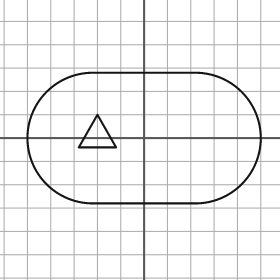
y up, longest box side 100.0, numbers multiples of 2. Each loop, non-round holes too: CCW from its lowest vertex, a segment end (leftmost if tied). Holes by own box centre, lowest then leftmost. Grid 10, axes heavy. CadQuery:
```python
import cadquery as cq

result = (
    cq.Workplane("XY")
    .moveTo(-22.0, -28.0)
    .lineTo(22.0, -28.0)
    .threePointArc((50.0, 0.0), (22.0, 28.0))
    .lineTo(-22.0, 28.0)
    .threePointArc((-50.0, 0.0), (-22.0, -28.0))
    .close()
    .moveTo(-28.0, -4.0)
    .lineTo(-12.0, -4.0)
    .lineTo(-20.0, 10.0)
    .close()
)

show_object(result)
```